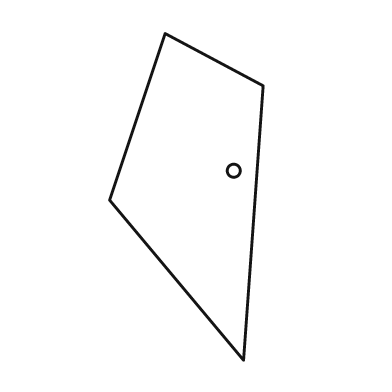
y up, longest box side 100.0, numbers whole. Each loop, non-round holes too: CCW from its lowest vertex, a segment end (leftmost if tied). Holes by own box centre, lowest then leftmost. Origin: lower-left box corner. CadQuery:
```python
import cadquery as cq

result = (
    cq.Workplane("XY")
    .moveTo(41.0, 0.0)
    .lineTo(47.0, 84.0)
    .lineTo(17.0, 100.0)
    .lineTo(0.0, 49.0)
    .close()
    .moveTo(38.0, 58.0)
    .circle(2.0)
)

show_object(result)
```